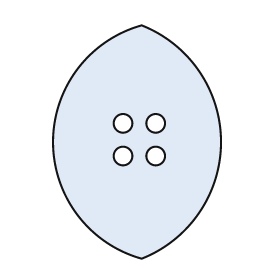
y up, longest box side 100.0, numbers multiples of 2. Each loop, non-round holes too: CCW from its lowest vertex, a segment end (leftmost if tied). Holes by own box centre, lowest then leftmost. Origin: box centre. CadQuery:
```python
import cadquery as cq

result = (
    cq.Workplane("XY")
    .moveTo(2.0, -50.0)
    .threePointArc((36.0, 0.0), (2.0, 50.0))
    .threePointArc((-36.0, 0.0), (2.0, -50.0))
    .close()
    .moveTo(-6.0, -6.0)
    .circle(4.0)
    .moveTo(8.0, -6.0)
    .circle(4.0)
    .moveTo(-6.0, 8.0)
    .circle(4.0)
    .moveTo(8.0, 8.0)
    .circle(4.0)
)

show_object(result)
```